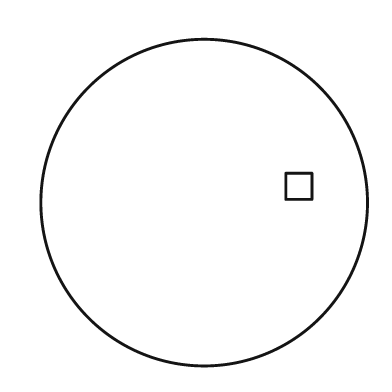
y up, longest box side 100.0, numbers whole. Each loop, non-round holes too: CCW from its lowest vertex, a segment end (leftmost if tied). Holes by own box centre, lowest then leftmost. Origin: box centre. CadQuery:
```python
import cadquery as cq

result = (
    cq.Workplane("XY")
    .moveTo(0.0, 0.0)
    .circle(50.0)
    .moveTo(25.0, 1.0)
    .lineTo(33.0, 1.0)
    .lineTo(33.0, 9.0)
    .lineTo(25.0, 9.0)
    .close()
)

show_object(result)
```